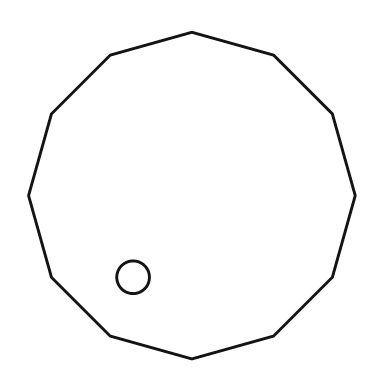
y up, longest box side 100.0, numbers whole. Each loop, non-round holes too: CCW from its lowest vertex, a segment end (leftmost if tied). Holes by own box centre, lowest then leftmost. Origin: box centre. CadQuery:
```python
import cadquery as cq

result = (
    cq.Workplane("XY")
    .moveTo(0.0, -50.0)
    .lineTo(25.0, -43.0)
    .lineTo(43.0, -25.0)
    .lineTo(50.0, 0.0)
    .lineTo(43.0, 25.0)
    .lineTo(25.0, 43.0)
    .lineTo(0.0, 50.0)
    .lineTo(-25.0, 43.0)
    .lineTo(-43.0, 25.0)
    .lineTo(-50.0, 0.0)
    .lineTo(-43.0, -25.0)
    .lineTo(-25.0, -43.0)
    .close()
    .moveTo(-18.0, -25.0)
    .circle(5.0)
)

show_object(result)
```